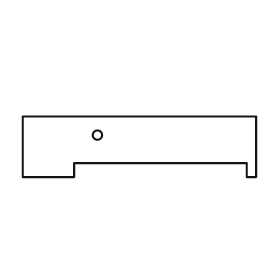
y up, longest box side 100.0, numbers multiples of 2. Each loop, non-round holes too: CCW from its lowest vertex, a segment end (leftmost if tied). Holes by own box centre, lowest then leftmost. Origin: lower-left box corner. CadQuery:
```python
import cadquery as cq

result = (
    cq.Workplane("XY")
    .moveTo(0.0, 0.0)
    .lineTo(22.0, 0.0)
    .lineTo(22.0, 6.0)
    .lineTo(96.0, 6.0)
    .lineTo(96.0, 0.0)
    .lineTo(100.0, 0.0)
    .lineTo(100.0, 26.0)
    .lineTo(0.0, 26.0)
    .close()
    .moveTo(32.0, 18.0)
    .circle(2.0)
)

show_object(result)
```